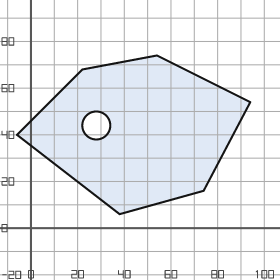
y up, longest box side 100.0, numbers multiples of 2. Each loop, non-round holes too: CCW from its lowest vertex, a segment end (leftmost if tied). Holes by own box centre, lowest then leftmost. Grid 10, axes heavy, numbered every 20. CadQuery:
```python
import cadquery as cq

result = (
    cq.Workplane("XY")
    .moveTo(38.0, 6.0)
    .lineTo(74.0, 16.0)
    .lineTo(94.0, 54.0)
    .lineTo(54.0, 74.0)
    .lineTo(22.0, 68.0)
    .lineTo(-6.0, 40.0)
    .close()
    .moveTo(28.0, 44.0)
    .circle(6.0)
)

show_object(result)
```